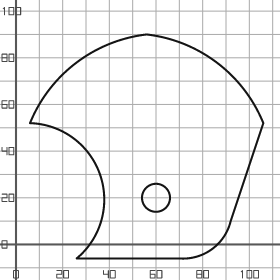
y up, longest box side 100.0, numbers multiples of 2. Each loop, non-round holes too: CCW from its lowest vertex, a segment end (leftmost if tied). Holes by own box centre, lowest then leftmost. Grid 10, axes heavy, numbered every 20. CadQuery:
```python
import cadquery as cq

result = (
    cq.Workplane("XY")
    .moveTo(26.0, -6.0)
    .lineTo(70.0, -6.0)
    .threePointArc((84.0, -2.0), (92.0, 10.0))
    .lineTo(106.0, 52.0)
    .threePointArc((86.0, 78.0), (56.0, 90.0))
    .threePointArc((26.0, 78.0), (6.0, 52.0))
    .threePointArc((36.0, 30.0), (26.0, -6.0))
    .close()
    .moveTo(60.0, 20.0)
    .circle(6.0)
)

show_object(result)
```